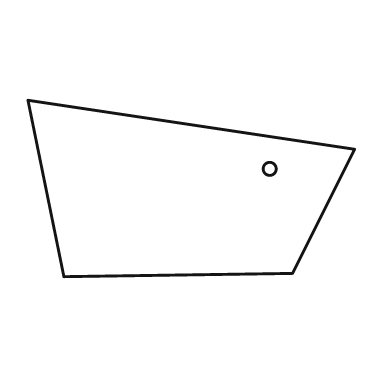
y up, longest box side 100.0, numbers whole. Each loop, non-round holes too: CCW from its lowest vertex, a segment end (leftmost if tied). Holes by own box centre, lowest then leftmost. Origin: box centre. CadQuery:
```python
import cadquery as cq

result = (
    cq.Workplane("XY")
    .moveTo(-39.0, -27.0)
    .lineTo(31.0, -26.0)
    .lineTo(50.0, 12.0)
    .lineTo(-50.0, 27.0)
    .close()
    .moveTo(24.0, 6.0)
    .circle(2.0)
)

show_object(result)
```